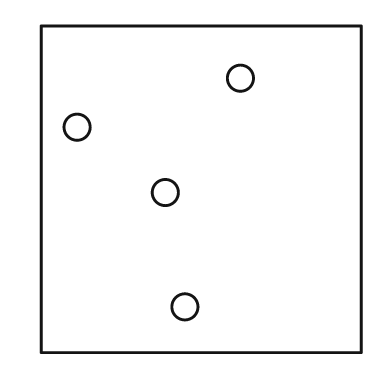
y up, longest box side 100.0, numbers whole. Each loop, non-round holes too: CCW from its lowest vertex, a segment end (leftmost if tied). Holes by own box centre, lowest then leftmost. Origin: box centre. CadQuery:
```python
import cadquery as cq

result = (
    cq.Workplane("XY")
    .moveTo(-49.0, -50.0)
    .lineTo(49.0, -50.0)
    .lineTo(49.0, 50.0)
    .lineTo(-49.0, 50.0)
    .close()
    .moveTo(-5.0, -36.0)
    .circle(4.0)
    .moveTo(-11.0, -1.0)
    .circle(4.0)
    .moveTo(-38.0, 19.0)
    .circle(4.0)
    .moveTo(12.0, 34.0)
    .circle(4.0)
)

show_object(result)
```